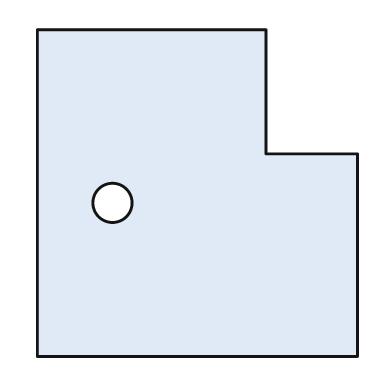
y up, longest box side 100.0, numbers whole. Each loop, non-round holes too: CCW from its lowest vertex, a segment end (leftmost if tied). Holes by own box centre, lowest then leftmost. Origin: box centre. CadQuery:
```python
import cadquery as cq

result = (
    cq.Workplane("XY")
    .moveTo(-49.0, -50.0)
    .lineTo(49.0, -50.0)
    .lineTo(49.0, 12.0)
    .lineTo(21.0, 12.0)
    .lineTo(21.0, 50.0)
    .lineTo(-49.0, 50.0)
    .close()
    .moveTo(-26.0, -3.0)
    .circle(6.0)
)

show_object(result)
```